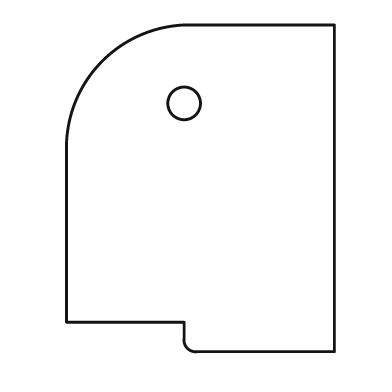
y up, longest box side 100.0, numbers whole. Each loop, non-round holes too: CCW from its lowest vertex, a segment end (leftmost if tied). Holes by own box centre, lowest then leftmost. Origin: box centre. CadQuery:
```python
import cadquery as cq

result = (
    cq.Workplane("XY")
    .moveTo(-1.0, -50.0)
    .lineTo(41.0, -50.0)
    .lineTo(41.0, 50.0)
    .lineTo(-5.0, 50.0)
    .threePointArc((-30.0, 39.0), (-41.0, 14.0))
    .lineTo(-41.0, -41.0)
    .lineTo(-5.0, -41.0)
    .lineTo(-5.0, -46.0)
    .threePointArc((-4.0, -49.0), (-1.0, -50.0))
    .close()
    .moveTo(-5.0, 26.0)
    .circle(5.0)
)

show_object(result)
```